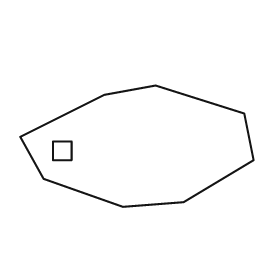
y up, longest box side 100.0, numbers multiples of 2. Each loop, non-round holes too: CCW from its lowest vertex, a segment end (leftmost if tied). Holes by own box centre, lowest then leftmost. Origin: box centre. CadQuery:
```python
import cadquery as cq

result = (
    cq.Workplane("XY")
    .moveTo(-6.0, -26.0)
    .lineTo(20.0, -24.0)
    .lineTo(50.0, -6.0)
    .lineTo(46.0, 14.0)
    .lineTo(8.0, 26.0)
    .lineTo(-14.0, 22.0)
    .lineTo(-50.0, 4.0)
    .lineTo(-40.0, -14.0)
    .close()
    .moveTo(-36.0, -6.0)
    .lineTo(-28.0, -6.0)
    .lineTo(-28.0, 2.0)
    .lineTo(-36.0, 2.0)
    .close()
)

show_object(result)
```